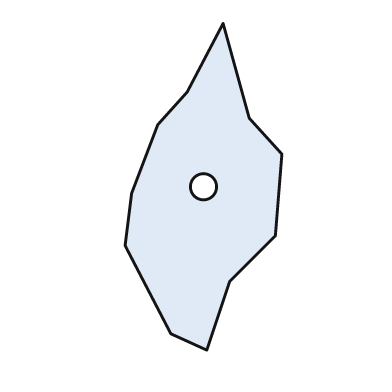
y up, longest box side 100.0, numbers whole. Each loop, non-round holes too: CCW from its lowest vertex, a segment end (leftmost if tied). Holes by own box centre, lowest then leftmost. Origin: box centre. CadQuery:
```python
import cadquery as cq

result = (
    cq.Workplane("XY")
    .moveTo(1.0, -50.0)
    .lineTo(8.0, -29.0)
    .lineTo(22.0, -15.0)
    .lineTo(24.0, 10.0)
    .lineTo(14.0, 21.0)
    .lineTo(6.0, 50.0)
    .lineTo(-5.0, 29.0)
    .lineTo(-14.0, 19.0)
    .lineTo(-22.0, -2.0)
    .lineTo(-24.0, -18.0)
    .lineTo(-10.0, -45.0)
    .close()
    .moveTo(0.0, 0.0)
    .circle(4.0)
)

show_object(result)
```